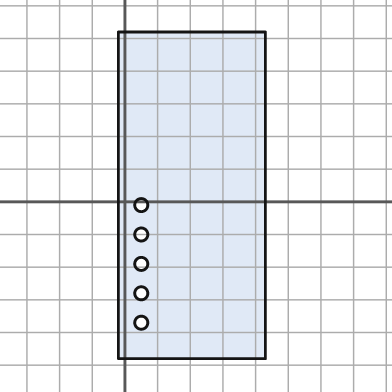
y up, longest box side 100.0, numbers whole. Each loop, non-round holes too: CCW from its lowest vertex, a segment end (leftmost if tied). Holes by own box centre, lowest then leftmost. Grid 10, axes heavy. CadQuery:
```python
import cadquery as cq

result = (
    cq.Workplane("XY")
    .moveTo(-2.0, -48.0)
    .lineTo(43.0, -48.0)
    .lineTo(43.0, 52.0)
    .lineTo(-2.0, 52.0)
    .close()
    .moveTo(5.0, -37.0)
    .circle(2.0)
    .moveTo(5.0, -28.0)
    .circle(2.0)
    .moveTo(5.0, -19.0)
    .circle(2.0)
    .moveTo(5.0, -10.0)
    .circle(2.0)
    .moveTo(5.0, -1.0)
    .circle(2.0)
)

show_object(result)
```